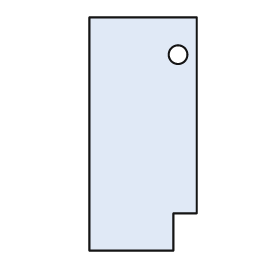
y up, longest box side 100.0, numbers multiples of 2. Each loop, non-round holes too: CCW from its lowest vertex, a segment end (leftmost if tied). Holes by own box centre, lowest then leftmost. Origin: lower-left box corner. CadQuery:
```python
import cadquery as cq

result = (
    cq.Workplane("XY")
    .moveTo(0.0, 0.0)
    .lineTo(36.0, 0.0)
    .lineTo(36.0, 16.0)
    .lineTo(46.0, 16.0)
    .lineTo(46.0, 100.0)
    .lineTo(0.0, 100.0)
    .close()
    .moveTo(38.0, 84.0)
    .circle(4.0)
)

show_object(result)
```